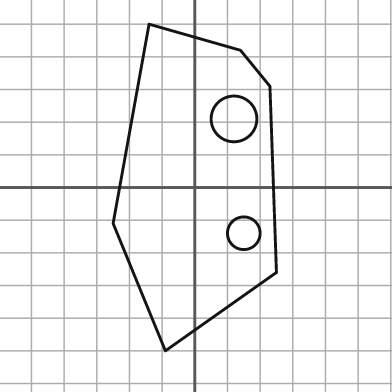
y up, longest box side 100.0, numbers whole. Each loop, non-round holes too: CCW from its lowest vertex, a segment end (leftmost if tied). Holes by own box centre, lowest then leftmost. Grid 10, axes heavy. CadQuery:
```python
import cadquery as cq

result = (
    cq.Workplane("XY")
    .moveTo(-9.0, -50.0)
    .lineTo(25.0, -26.0)
    .lineTo(23.0, 31.0)
    .lineTo(14.0, 42.0)
    .lineTo(-14.0, 50.0)
    .lineTo(-25.0, -11.0)
    .close()
    .moveTo(15.0, -14.0)
    .circle(5.0)
    .moveTo(12.0, 21.0)
    .circle(7.0)
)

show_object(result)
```